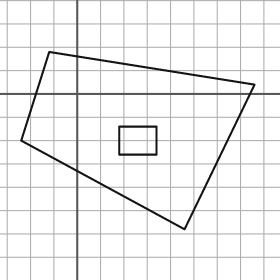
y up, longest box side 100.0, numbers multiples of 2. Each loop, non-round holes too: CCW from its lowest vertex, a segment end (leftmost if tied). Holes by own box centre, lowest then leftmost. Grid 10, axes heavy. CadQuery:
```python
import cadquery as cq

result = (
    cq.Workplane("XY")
    .moveTo(46.0, -58.0)
    .lineTo(76.0, 4.0)
    .lineTo(-12.0, 18.0)
    .lineTo(-24.0, -20.0)
    .close()
    .moveTo(18.0, -26.0)
    .lineTo(34.0, -26.0)
    .lineTo(34.0, -14.0)
    .lineTo(18.0, -14.0)
    .close()
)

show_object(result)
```